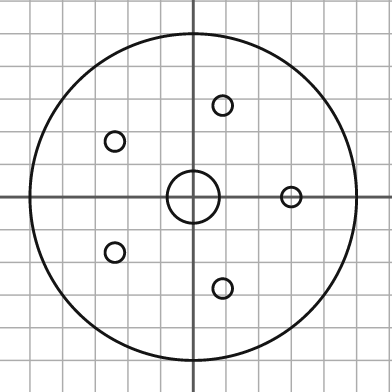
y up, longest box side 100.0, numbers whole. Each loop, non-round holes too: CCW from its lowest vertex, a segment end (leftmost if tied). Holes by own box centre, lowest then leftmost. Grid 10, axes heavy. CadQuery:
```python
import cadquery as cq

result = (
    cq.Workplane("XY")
    .moveTo(0.0, 0.0)
    .circle(50.0)
    .moveTo(9.0, -28.0)
    .circle(3.0)
    .moveTo(-24.0, -17.0)
    .circle(3.0)
    .moveTo(0.0, 0.0)
    .circle(8.0)
    .moveTo(30.0, 0.0)
    .circle(3.0)
    .moveTo(-24.0, 17.0)
    .circle(3.0)
    .moveTo(9.0, 28.0)
    .circle(3.0)
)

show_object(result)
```